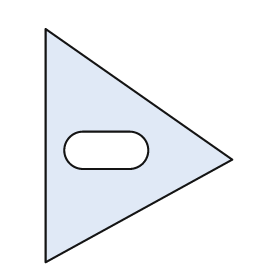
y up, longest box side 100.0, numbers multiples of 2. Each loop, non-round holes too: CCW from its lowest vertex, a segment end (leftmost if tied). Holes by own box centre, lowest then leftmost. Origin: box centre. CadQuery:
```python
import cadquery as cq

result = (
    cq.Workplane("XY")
    .moveTo(-40.0, -50.0)
    .lineTo(40.0, -6.0)
    .lineTo(-40.0, 50.0)
    .close()
    .moveTo(-24.0, -10.0)
    .lineTo(-4.0, -10.0)
    .threePointArc((4.0, -2.0), (-4.0, 6.0))
    .lineTo(-24.0, 6.0)
    .threePointArc((-32.0, -2.0), (-24.0, -10.0))
    .close()
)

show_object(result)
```